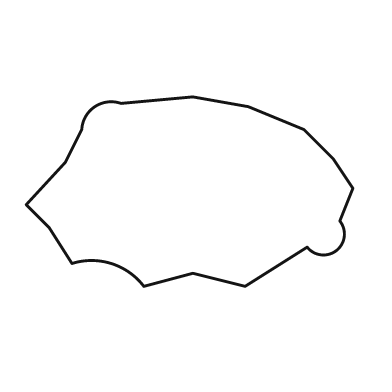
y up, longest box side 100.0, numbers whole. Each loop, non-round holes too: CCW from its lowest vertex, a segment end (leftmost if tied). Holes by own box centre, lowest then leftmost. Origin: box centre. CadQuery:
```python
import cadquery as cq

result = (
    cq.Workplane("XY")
    .moveTo(-14.0, -29.0)
    .lineTo(1.0, -25.0)
    .lineTo(17.0, -29.0)
    .lineTo(36.0, -17.0)
    .threePointArc((45.0, -18.0), (46.0, -9.0))
    .lineTo(50.0, 1.0)
    .lineTo(44.0, 10.0)
    .lineTo(35.0, 19.0)
    .lineTo(18.0, 26.0)
    .lineTo(1.0, 29.0)
    .lineTo(-21.0, 27.0)
    .threePointArc((-29.0, 26.0), (-33.0, 19.0))
    .lineTo(-38.0, 9.0)
    .lineTo(-50.0, -4.0)
    .lineTo(-43.0, -11.0)
    .lineTo(-36.0, -22.0)
    .threePointArc((-24.0, -22.0), (-14.0, -29.0))
    .close()
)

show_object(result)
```